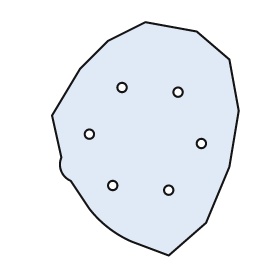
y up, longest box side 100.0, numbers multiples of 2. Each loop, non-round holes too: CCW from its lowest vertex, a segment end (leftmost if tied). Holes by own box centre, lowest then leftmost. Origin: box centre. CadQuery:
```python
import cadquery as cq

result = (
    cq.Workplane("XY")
    .moveTo(10.0, -50.0)
    .lineTo(26.0, -36.0)
    .lineTo(36.0, -12.0)
    .lineTo(40.0, 12.0)
    .lineTo(36.0, 34.0)
    .lineTo(22.0, 46.0)
    .lineTo(0.0, 50.0)
    .lineTo(-16.0, 42.0)
    .lineTo(-28.0, 30.0)
    .lineTo(-40.0, 10.0)
    .lineTo(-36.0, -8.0)
    .threePointArc((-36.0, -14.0), (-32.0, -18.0))
    .lineTo(-24.0, -30.0)
    .threePointArc((-16.0, -38.0), (-6.0, -44.0))
    .close()
    .moveTo(10.0, -22.0)
    .circle(2.0)
    .moveTo(-14.0, -20.0)
    .circle(2.0)
    .moveTo(24.0, -2.0)
    .circle(2.0)
    .moveTo(-24.0, 2.0)
    .circle(2.0)
    .moveTo(14.0, 20.0)
    .circle(2.0)
    .moveTo(-10.0, 22.0)
    .circle(2.0)
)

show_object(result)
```